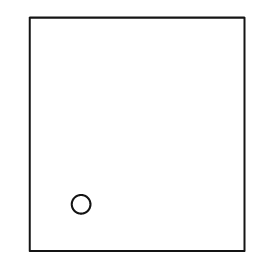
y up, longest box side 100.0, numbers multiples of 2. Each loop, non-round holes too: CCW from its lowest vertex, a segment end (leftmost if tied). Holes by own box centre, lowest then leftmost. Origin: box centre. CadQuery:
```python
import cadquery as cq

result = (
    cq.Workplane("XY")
    .moveTo(-46.0, -50.0)
    .lineTo(46.0, -50.0)
    .lineTo(46.0, 50.0)
    .lineTo(-46.0, 50.0)
    .close()
    .moveTo(-24.0, -30.0)
    .circle(4.0)
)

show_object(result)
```